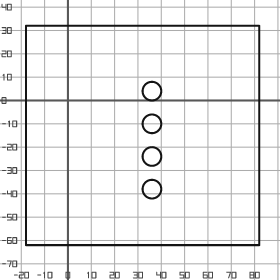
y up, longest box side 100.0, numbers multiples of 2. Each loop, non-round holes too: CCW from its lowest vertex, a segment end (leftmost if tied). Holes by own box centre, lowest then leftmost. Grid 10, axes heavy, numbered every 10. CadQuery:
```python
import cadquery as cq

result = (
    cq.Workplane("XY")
    .moveTo(-18.0, -62.0)
    .lineTo(82.0, -62.0)
    .lineTo(82.0, 32.0)
    .lineTo(-18.0, 32.0)
    .close()
    .moveTo(36.0, -38.0)
    .circle(4.0)
    .moveTo(36.0, -24.0)
    .circle(4.0)
    .moveTo(36.0, -10.0)
    .circle(4.0)
    .moveTo(36.0, 4.0)
    .circle(4.0)
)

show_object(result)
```